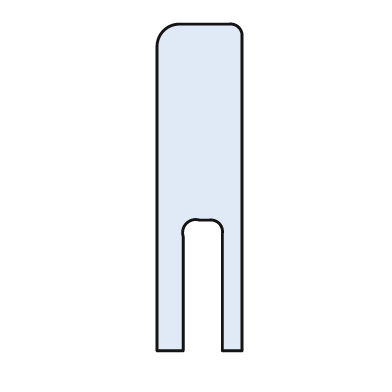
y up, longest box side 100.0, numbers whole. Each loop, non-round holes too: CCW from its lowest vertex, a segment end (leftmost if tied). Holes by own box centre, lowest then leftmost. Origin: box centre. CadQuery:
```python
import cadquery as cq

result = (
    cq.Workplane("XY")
    .moveTo(-13.0, -50.0)
    .lineTo(-5.0, -50.0)
    .lineTo(-5.0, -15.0)
    .threePointArc((-4.0, -11.0), (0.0, -10.0))
    .lineTo(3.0, -10.0)
    .threePointArc((6.0, -11.0), (7.0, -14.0))
    .lineTo(7.0, -50.0)
    .lineTo(13.0, -50.0)
    .lineTo(13.0, 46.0)
    .threePointArc((12.0, 49.0), (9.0, 50.0))
    .lineTo(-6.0, 50.0)
    .threePointArc((-11.0, 48.0), (-13.0, 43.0))
    .close()
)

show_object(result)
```